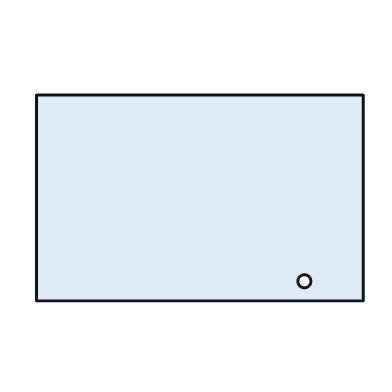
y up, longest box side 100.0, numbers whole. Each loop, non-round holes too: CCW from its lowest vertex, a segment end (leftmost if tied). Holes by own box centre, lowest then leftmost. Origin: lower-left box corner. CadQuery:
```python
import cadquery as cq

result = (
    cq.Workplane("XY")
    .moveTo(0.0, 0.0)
    .lineTo(100.0, 0.0)
    .lineTo(100.0, 63.0)
    .lineTo(0.0, 63.0)
    .close()
    .moveTo(82.0, 6.0)
    .circle(2.0)
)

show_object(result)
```